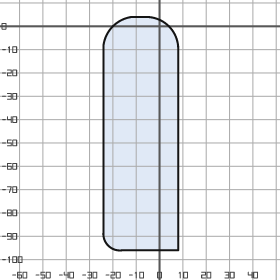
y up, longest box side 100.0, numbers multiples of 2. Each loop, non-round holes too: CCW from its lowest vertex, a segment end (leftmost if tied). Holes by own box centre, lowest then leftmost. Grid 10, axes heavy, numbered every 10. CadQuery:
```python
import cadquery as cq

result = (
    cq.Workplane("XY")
    .moveTo(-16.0, -96.0)
    .lineTo(8.0, -96.0)
    .lineTo(8.0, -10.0)
    .threePointArc((4.0, 0.0), (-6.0, 4.0))
    .lineTo(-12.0, 4.0)
    .threePointArc((-20.0, 0.0), (-24.0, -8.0))
    .lineTo(-24.0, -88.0)
    .threePointArc((-22.0, -94.0), (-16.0, -96.0))
    .close()
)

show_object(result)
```